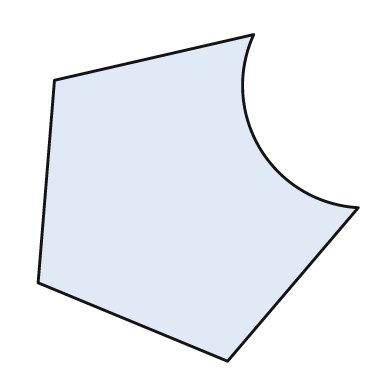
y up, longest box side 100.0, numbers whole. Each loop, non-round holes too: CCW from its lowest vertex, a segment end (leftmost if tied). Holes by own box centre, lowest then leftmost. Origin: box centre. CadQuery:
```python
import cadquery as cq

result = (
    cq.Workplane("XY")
    .moveTo(9.0, -50.0)
    .lineTo(49.0, -3.0)
    .threePointArc((19.0, 15.0), (17.0, 50.0))
    .lineTo(-44.0, 36.0)
    .lineTo(-49.0, -26.0)
    .close()
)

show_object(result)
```